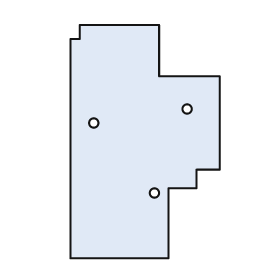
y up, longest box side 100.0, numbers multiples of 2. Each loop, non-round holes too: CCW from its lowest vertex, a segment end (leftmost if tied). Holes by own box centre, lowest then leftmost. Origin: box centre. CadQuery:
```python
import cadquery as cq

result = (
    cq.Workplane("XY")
    .moveTo(-32.0, -50.0)
    .lineTo(10.0, -50.0)
    .lineTo(10.0, -20.0)
    .lineTo(22.0, -20.0)
    .lineTo(22.0, -12.0)
    .lineTo(32.0, -12.0)
    .lineTo(32.0, 28.0)
    .lineTo(6.0, 28.0)
    .lineTo(6.0, 50.0)
    .lineTo(-28.0, 50.0)
    .lineTo(-28.0, 44.0)
    .lineTo(-32.0, 44.0)
    .close()
    .moveTo(4.0, -22.0)
    .circle(2.0)
    .moveTo(-22.0, 8.0)
    .circle(2.0)
    .moveTo(18.0, 14.0)
    .circle(2.0)
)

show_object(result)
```